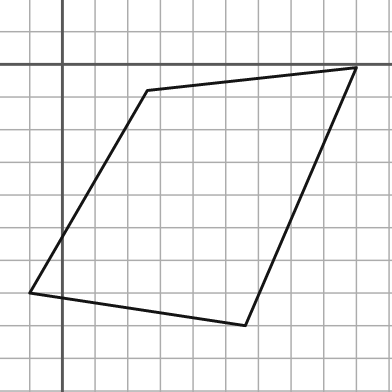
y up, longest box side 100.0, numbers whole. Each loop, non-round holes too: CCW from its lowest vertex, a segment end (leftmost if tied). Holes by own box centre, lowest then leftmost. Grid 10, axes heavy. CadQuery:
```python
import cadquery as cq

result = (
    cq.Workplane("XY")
    .moveTo(56.0, -80.0)
    .lineTo(90.0, -1.0)
    .lineTo(26.0, -8.0)
    .lineTo(-10.0, -70.0)
    .close()
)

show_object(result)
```